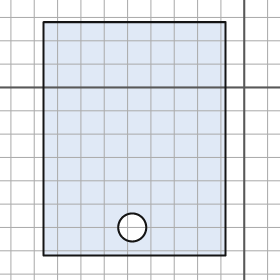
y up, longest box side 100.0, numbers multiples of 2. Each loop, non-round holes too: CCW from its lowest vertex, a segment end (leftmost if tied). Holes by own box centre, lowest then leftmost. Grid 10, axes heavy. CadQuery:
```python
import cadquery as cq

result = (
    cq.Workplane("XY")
    .moveTo(-86.0, -72.0)
    .lineTo(-8.0, -72.0)
    .lineTo(-8.0, 28.0)
    .lineTo(-86.0, 28.0)
    .close()
    .moveTo(-48.0, -60.0)
    .circle(6.0)
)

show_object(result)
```